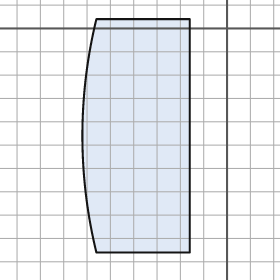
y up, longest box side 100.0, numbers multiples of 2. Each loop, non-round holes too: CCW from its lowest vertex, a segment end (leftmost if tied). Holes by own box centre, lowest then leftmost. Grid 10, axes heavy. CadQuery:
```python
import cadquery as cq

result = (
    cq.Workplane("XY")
    .moveTo(-56.0, -96.0)
    .lineTo(-16.0, -96.0)
    .lineTo(-16.0, 4.0)
    .lineTo(-56.0, 4.0)
    .threePointArc((-62.0, -46.0), (-56.0, -96.0))
    .close()
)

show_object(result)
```